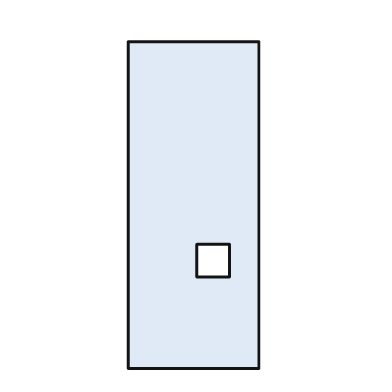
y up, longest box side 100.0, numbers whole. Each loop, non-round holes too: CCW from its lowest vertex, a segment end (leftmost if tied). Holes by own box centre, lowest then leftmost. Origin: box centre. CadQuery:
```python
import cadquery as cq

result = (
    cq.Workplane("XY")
    .moveTo(-20.0, -50.0)
    .lineTo(20.0, -50.0)
    .lineTo(20.0, 50.0)
    .lineTo(-20.0, 50.0)
    .close()
    .moveTo(1.0, -22.0)
    .lineTo(11.0, -22.0)
    .lineTo(11.0, -12.0)
    .lineTo(1.0, -12.0)
    .close()
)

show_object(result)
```